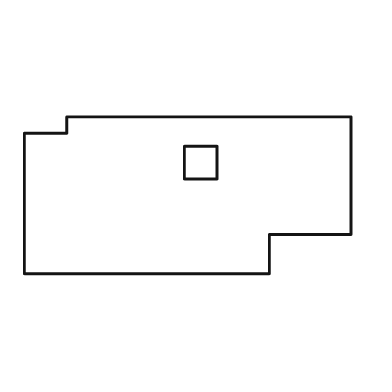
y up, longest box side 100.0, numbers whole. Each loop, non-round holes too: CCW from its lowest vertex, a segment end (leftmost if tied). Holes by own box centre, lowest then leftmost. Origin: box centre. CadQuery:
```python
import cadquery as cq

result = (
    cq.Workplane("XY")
    .moveTo(-50.0, -24.0)
    .lineTo(25.0, -24.0)
    .lineTo(25.0, -12.0)
    .lineTo(50.0, -12.0)
    .lineTo(50.0, 24.0)
    .lineTo(-37.0, 24.0)
    .lineTo(-37.0, 19.0)
    .lineTo(-50.0, 19.0)
    .close()
    .moveTo(-1.0, 5.0)
    .lineTo(9.0, 5.0)
    .lineTo(9.0, 15.0)
    .lineTo(-1.0, 15.0)
    .close()
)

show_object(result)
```